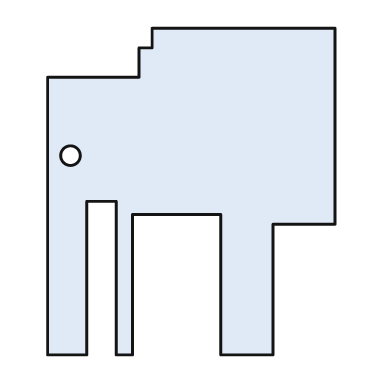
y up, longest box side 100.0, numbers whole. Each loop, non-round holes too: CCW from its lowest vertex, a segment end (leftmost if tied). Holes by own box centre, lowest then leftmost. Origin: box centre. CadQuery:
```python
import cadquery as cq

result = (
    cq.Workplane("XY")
    .moveTo(-44.0, -50.0)
    .lineTo(-32.0, -50.0)
    .lineTo(-32.0, -3.0)
    .lineTo(-23.0, -3.0)
    .lineTo(-23.0, -50.0)
    .lineTo(-18.0, -50.0)
    .lineTo(-18.0, -7.0)
    .lineTo(9.0, -7.0)
    .lineTo(9.0, -50.0)
    .lineTo(25.0, -50.0)
    .lineTo(25.0, -10.0)
    .lineTo(44.0, -10.0)
    .lineTo(44.0, 50.0)
    .lineTo(-12.0, 50.0)
    .lineTo(-12.0, 44.0)
    .lineTo(-16.0, 44.0)
    .lineTo(-16.0, 35.0)
    .lineTo(-44.0, 35.0)
    .close()
    .moveTo(-37.0, 11.0)
    .circle(3.0)
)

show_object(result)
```